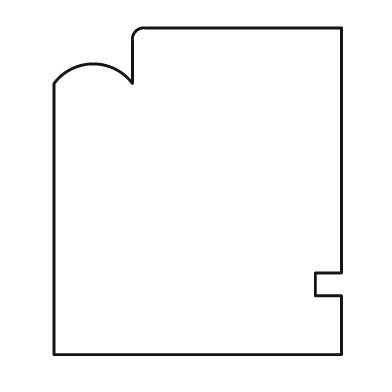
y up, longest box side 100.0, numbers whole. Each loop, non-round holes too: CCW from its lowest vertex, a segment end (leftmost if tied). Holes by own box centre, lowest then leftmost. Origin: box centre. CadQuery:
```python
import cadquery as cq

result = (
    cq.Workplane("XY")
    .moveTo(-44.0, -50.0)
    .lineTo(44.0, -50.0)
    .lineTo(44.0, -32.0)
    .lineTo(36.0, -32.0)
    .lineTo(36.0, -25.0)
    .lineTo(44.0, -25.0)
    .lineTo(44.0, 50.0)
    .lineTo(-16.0, 50.0)
    .threePointArc((-19.0, 49.0), (-20.0, 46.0))
    .lineTo(-20.0, 33.0)
    .threePointArc((-32.0, 39.0), (-44.0, 33.0))
    .close()
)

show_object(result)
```